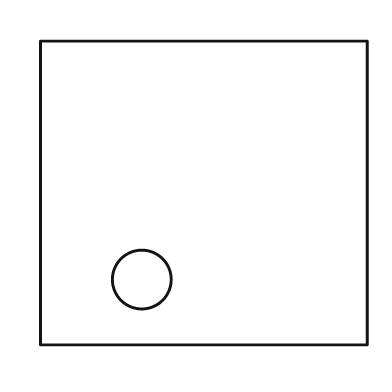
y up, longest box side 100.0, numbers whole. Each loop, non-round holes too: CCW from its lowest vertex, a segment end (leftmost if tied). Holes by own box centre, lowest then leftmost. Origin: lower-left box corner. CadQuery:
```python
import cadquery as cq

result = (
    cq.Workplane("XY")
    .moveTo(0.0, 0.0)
    .lineTo(100.0, 0.0)
    .lineTo(100.0, 93.0)
    .lineTo(0.0, 93.0)
    .close()
    .moveTo(31.0, 20.0)
    .circle(9.0)
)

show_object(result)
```